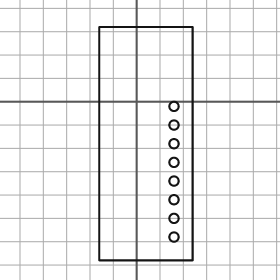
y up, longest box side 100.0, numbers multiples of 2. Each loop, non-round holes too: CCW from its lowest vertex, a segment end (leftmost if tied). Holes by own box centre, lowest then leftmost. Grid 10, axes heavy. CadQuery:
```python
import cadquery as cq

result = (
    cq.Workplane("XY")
    .moveTo(-16.0, -68.0)
    .lineTo(24.0, -68.0)
    .lineTo(24.0, 32.0)
    .lineTo(-16.0, 32.0)
    .close()
    .moveTo(16.0, -58.0)
    .circle(2.0)
    .moveTo(16.0, -50.0)
    .circle(2.0)
    .moveTo(16.0, -42.0)
    .circle(2.0)
    .moveTo(16.0, -34.0)
    .circle(2.0)
    .moveTo(16.0, -26.0)
    .circle(2.0)
    .moveTo(16.0, -18.0)
    .circle(2.0)
    .moveTo(16.0, -10.0)
    .circle(2.0)
    .moveTo(16.0, -2.0)
    .circle(2.0)
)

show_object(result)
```